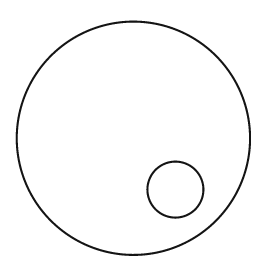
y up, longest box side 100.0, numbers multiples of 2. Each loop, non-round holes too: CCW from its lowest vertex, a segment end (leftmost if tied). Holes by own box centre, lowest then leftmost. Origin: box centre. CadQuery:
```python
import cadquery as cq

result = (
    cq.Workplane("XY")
    .moveTo(0.0, 0.0)
    .circle(50.0)
    .moveTo(18.0, -22.0)
    .circle(12.0)
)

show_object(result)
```